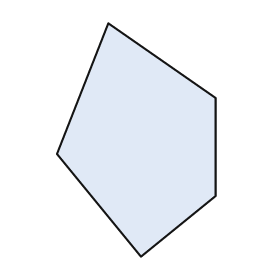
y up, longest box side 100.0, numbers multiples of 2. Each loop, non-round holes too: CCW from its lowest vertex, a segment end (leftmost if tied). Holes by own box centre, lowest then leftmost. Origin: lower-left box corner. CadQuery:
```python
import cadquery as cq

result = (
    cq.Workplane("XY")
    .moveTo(36.0, 0.0)
    .lineTo(68.0, 26.0)
    .lineTo(68.0, 68.0)
    .lineTo(22.0, 100.0)
    .lineTo(0.0, 44.0)
    .close()
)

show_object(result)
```